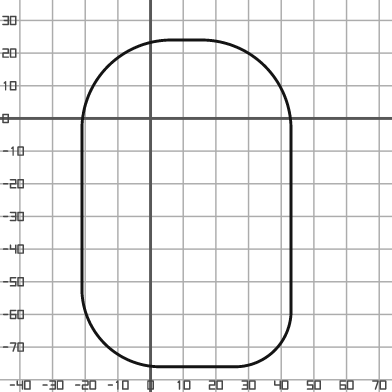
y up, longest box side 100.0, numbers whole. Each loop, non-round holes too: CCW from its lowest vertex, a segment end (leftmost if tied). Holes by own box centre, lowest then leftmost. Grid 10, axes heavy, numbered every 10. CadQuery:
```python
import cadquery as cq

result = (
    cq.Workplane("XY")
    .moveTo(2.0, -76.0)
    .lineTo(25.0, -76.0)
    .threePointArc((38.0, -71.0), (43.0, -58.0))
    .lineTo(43.0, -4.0)
    .threePointArc((35.0, 16.0), (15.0, 24.0))
    .lineTo(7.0, 24.0)
    .threePointArc((-13.0, 16.0), (-21.0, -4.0))
    .lineTo(-21.0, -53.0)
    .threePointArc((-14.0, -69.0), (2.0, -76.0))
    .close()
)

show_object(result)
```